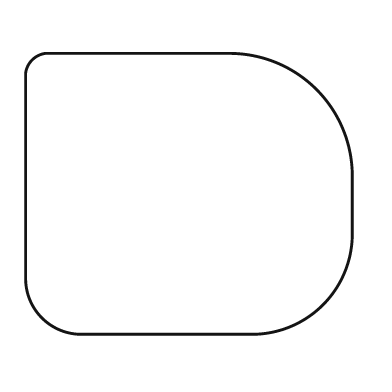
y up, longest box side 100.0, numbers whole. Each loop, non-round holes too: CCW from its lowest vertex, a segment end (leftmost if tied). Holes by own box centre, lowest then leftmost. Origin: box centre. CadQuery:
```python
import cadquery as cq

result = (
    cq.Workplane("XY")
    .moveTo(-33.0, -43.0)
    .lineTo(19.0, -43.0)
    .threePointArc((41.0, -34.0), (50.0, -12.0))
    .lineTo(50.0, 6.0)
    .threePointArc((39.0, 32.0), (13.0, 43.0))
    .lineTo(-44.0, 43.0)
    .threePointArc((-48.0, 41.0), (-50.0, 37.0))
    .lineTo(-50.0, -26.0)
    .threePointArc((-45.0, -38.0), (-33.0, -43.0))
    .close()
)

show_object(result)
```